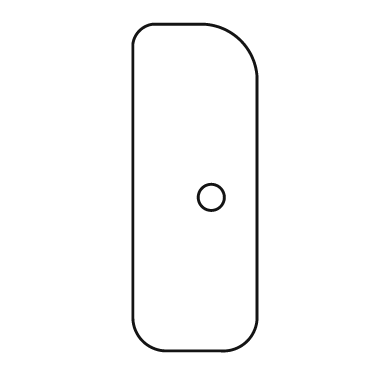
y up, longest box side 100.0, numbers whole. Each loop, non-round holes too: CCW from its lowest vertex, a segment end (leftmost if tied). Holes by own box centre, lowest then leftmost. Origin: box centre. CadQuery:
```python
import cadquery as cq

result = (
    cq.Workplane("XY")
    .moveTo(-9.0, -50.0)
    .lineTo(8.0, -50.0)
    .threePointArc((16.0, -47.0), (19.0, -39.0))
    .lineTo(19.0, 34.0)
    .threePointArc((14.0, 45.0), (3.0, 50.0))
    .lineTo(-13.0, 50.0)
    .threePointArc((-17.0, 48.0), (-19.0, 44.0))
    .lineTo(-19.0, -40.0)
    .threePointArc((-16.0, -47.0), (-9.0, -50.0))
    .close()
    .moveTo(5.0, -3.0)
    .circle(4.0)
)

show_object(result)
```